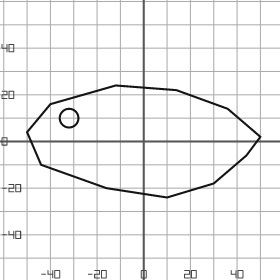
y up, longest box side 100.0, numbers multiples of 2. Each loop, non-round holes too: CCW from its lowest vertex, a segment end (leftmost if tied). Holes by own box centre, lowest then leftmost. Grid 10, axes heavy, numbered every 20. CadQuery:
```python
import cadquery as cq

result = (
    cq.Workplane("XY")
    .moveTo(10.0, -24.0)
    .lineTo(30.0, -18.0)
    .lineTo(44.0, -6.0)
    .lineTo(50.0, 2.0)
    .lineTo(36.0, 14.0)
    .lineTo(14.0, 22.0)
    .lineTo(-12.0, 24.0)
    .lineTo(-40.0, 16.0)
    .lineTo(-50.0, 4.0)
    .lineTo(-44.0, -10.0)
    .lineTo(-16.0, -20.0)
    .close()
    .moveTo(-32.0, 10.0)
    .circle(4.0)
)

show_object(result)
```